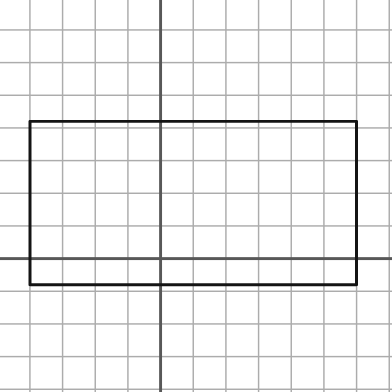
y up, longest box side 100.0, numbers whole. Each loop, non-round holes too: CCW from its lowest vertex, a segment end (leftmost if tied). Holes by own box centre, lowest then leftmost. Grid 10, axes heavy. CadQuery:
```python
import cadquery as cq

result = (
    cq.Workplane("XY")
    .moveTo(-40.0, -8.0)
    .lineTo(60.0, -8.0)
    .lineTo(60.0, 42.0)
    .lineTo(-40.0, 42.0)
    .close()
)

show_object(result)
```